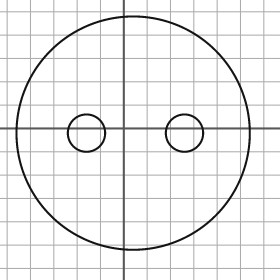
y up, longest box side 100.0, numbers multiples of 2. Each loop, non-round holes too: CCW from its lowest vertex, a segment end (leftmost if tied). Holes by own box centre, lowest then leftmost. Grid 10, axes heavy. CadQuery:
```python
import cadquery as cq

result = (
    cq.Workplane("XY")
    .moveTo(4.0, -2.0)
    .circle(50.0)
    .moveTo(-16.0, -2.0)
    .circle(8.0)
    .moveTo(26.0, -2.0)
    .circle(8.0)
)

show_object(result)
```